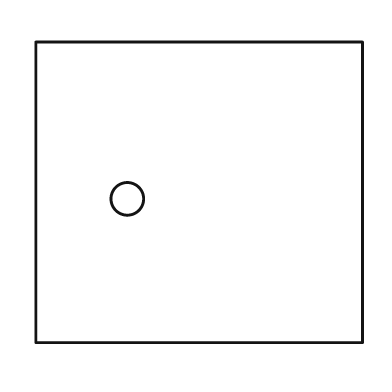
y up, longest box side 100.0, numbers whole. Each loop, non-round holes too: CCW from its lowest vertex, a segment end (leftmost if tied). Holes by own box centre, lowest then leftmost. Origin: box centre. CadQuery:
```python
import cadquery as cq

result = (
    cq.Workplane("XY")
    .moveTo(-50.0, -46.0)
    .lineTo(50.0, -46.0)
    .lineTo(50.0, 46.0)
    .lineTo(-50.0, 46.0)
    .close()
    .moveTo(-22.0, -2.0)
    .circle(5.0)
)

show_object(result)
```